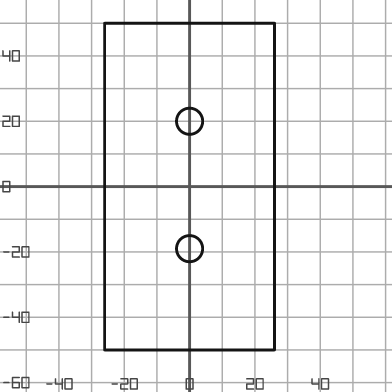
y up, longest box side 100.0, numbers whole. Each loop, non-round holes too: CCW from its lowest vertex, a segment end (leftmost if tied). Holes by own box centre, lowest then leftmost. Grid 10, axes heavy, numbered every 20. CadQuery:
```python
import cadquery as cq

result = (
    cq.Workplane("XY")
    .moveTo(-26.0, -50.0)
    .lineTo(26.0, -50.0)
    .lineTo(26.0, 50.0)
    .lineTo(-26.0, 50.0)
    .close()
    .moveTo(0.0, -19.0)
    .circle(4.0)
    .moveTo(0.0, 20.0)
    .circle(4.0)
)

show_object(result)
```